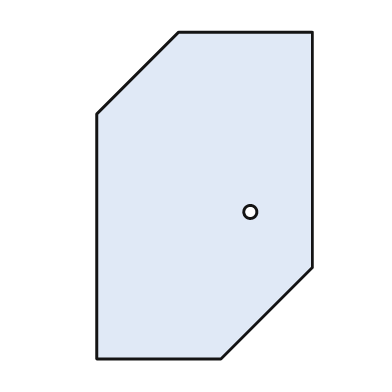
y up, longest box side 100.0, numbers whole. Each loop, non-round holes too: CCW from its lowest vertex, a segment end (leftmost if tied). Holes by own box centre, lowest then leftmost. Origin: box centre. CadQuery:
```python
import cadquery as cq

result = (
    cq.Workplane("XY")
    .moveTo(-33.0, -50.0)
    .lineTo(5.0, -50.0)
    .lineTo(33.0, -22.0)
    .lineTo(33.0, 50.0)
    .lineTo(-8.0, 50.0)
    .lineTo(-33.0, 25.0)
    .close()
    .moveTo(14.0, -5.0)
    .circle(2.0)
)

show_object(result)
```